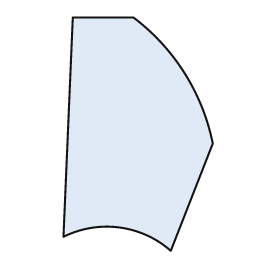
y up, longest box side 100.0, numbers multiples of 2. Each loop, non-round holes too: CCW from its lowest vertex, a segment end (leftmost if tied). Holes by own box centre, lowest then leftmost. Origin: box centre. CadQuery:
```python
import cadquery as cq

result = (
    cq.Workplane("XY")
    .moveTo(14.0, -50.0)
    .lineTo(32.0, -4.0)
    .threePointArc((20.0, 26.0), (-2.0, 50.0))
    .lineTo(-28.0, 50.0)
    .lineTo(-32.0, -44.0)
    .threePointArc((-8.0, -40.0), (14.0, -50.0))
    .close()
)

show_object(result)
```